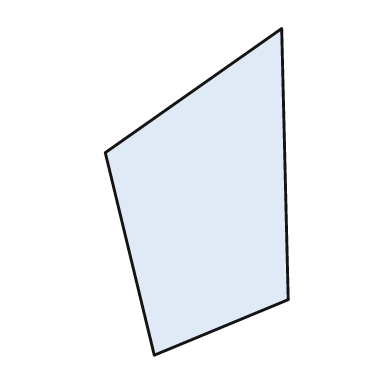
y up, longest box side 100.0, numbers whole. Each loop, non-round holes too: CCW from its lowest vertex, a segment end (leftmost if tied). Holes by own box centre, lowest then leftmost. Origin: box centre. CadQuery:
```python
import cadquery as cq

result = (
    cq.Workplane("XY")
    .moveTo(-13.0, -50.0)
    .lineTo(28.0, -33.0)
    .lineTo(26.0, 50.0)
    .lineTo(-28.0, 12.0)
    .close()
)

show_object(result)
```